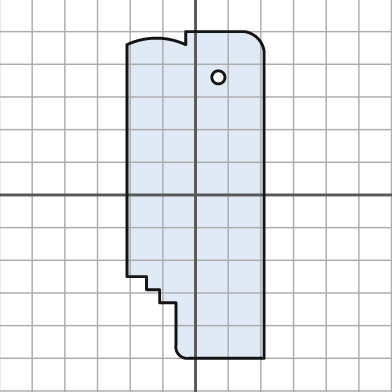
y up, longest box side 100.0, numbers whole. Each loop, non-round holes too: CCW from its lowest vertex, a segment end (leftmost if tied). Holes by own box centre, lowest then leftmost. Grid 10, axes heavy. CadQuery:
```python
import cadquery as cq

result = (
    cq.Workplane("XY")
    .moveTo(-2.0, -50.0)
    .lineTo(21.0, -50.0)
    .lineTo(21.0, 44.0)
    .threePointArc((19.0, 48.0), (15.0, 50.0))
    .lineTo(-3.0, 50.0)
    .lineTo(-3.0, 46.0)
    .threePointArc((-12.0, 48.0), (-21.0, 46.0))
    .lineTo(-21.0, -25.0)
    .lineTo(-15.0, -25.0)
    .lineTo(-15.0, -29.0)
    .lineTo(-11.0, -29.0)
    .lineTo(-11.0, -33.0)
    .lineTo(-6.0, -33.0)
    .lineTo(-6.0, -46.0)
    .threePointArc((-5.0, -49.0), (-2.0, -50.0))
    .close()
    .moveTo(7.0, 36.0)
    .circle(2.0)
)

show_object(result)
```